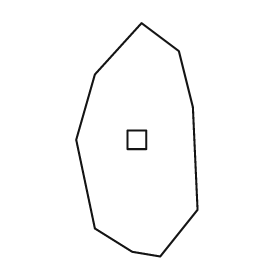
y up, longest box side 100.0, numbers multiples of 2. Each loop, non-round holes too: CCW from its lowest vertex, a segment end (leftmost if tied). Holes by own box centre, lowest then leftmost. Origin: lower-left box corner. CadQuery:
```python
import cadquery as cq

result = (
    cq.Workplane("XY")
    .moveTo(36.0, 0.0)
    .lineTo(52.0, 20.0)
    .lineTo(50.0, 64.0)
    .lineTo(44.0, 88.0)
    .lineTo(28.0, 100.0)
    .lineTo(8.0, 78.0)
    .lineTo(0.0, 50.0)
    .lineTo(8.0, 12.0)
    .lineTo(24.0, 2.0)
    .close()
    .moveTo(22.0, 46.0)
    .lineTo(30.0, 46.0)
    .lineTo(30.0, 54.0)
    .lineTo(22.0, 54.0)
    .close()
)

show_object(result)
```